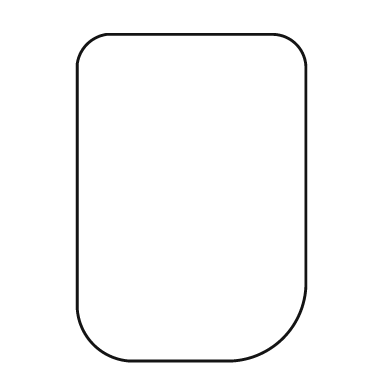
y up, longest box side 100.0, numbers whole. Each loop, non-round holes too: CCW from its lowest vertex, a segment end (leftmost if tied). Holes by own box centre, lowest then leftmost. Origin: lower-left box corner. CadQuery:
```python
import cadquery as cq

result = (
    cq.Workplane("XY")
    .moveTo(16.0, 0.0)
    .lineTo(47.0, 0.0)
    .threePointArc((63.0, 7.0), (70.0, 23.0))
    .lineTo(70.0, 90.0)
    .threePointArc((67.0, 97.0), (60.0, 100.0))
    .lineTo(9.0, 100.0)
    .threePointArc((3.0, 97.0), (0.0, 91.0))
    .lineTo(0.0, 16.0)
    .threePointArc((5.0, 5.0), (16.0, 0.0))
    .close()
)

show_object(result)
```